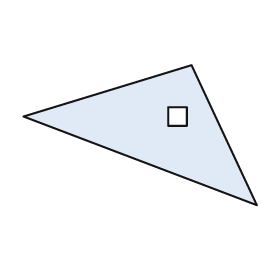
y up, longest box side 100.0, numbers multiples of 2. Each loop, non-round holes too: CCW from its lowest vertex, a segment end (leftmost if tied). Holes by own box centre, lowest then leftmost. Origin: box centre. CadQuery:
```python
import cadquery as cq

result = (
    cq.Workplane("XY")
    .moveTo(50.0, -30.0)
    .lineTo(22.0, 30.0)
    .lineTo(-50.0, 8.0)
    .close()
    .moveTo(12.0, 4.0)
    .lineTo(20.0, 4.0)
    .lineTo(20.0, 12.0)
    .lineTo(12.0, 12.0)
    .close()
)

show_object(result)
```